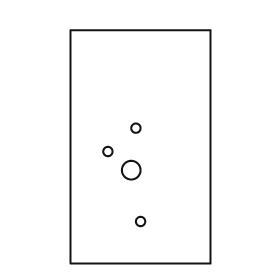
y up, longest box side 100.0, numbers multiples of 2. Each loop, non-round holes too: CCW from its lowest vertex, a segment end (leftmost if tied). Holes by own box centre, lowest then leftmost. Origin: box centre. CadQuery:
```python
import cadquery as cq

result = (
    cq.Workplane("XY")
    .moveTo(-30.0, -50.0)
    .lineTo(30.0, -50.0)
    .lineTo(30.0, 50.0)
    .lineTo(-30.0, 50.0)
    .close()
    .moveTo(0.0, -32.0)
    .circle(2.0)
    .moveTo(-4.0, -10.0)
    .circle(4.0)
    .moveTo(-14.0, -2.0)
    .circle(2.0)
    .moveTo(-2.0, 8.0)
    .circle(2.0)
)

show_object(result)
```